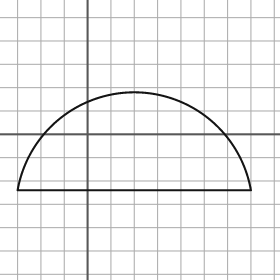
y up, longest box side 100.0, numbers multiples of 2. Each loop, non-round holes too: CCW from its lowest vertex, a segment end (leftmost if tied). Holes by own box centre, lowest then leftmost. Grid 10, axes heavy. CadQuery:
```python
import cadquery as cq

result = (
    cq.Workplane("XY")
    .moveTo(-30.0, -24.0)
    .lineTo(70.0, -24.0)
    .threePointArc((20.0, 18.0), (-30.0, -24.0))
    .close()
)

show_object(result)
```